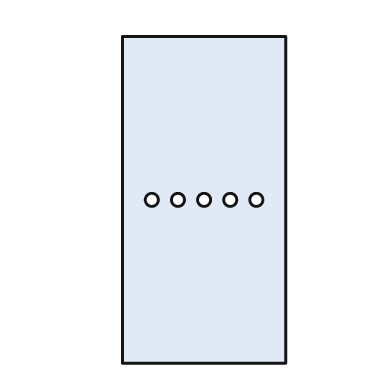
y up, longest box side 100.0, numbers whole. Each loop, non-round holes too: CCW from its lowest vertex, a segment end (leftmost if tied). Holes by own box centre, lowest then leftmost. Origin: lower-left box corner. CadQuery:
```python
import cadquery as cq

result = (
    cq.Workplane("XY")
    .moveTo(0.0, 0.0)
    .lineTo(50.0, 0.0)
    .lineTo(50.0, 100.0)
    .lineTo(0.0, 100.0)
    .close()
    .moveTo(9.0, 50.0)
    .circle(2.0)
    .moveTo(17.0, 50.0)
    .circle(2.0)
    .moveTo(25.0, 50.0)
    .circle(2.0)
    .moveTo(33.0, 50.0)
    .circle(2.0)
    .moveTo(41.0, 50.0)
    .circle(2.0)
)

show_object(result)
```